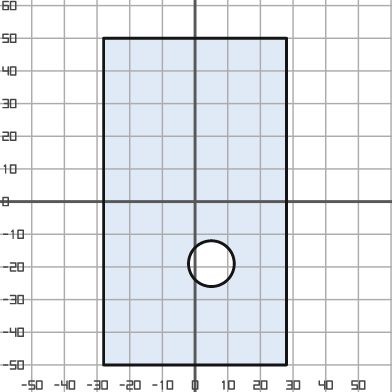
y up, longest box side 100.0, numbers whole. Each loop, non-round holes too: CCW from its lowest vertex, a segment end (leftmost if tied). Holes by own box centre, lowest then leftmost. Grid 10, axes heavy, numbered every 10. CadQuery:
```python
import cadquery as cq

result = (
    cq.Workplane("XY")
    .moveTo(-28.0, -50.0)
    .lineTo(28.0, -50.0)
    .lineTo(28.0, 50.0)
    .lineTo(-28.0, 50.0)
    .close()
    .moveTo(5.0, -19.0)
    .circle(7.0)
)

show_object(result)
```